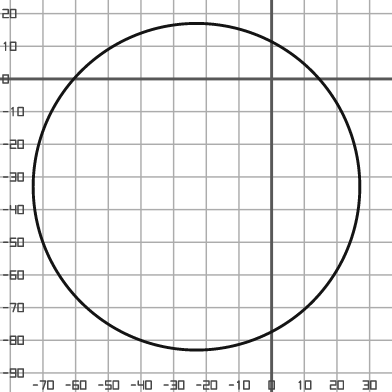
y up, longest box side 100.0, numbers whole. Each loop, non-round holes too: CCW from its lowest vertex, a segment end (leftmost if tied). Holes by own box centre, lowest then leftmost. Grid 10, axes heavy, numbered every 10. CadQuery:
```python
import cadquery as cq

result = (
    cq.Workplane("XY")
    .moveTo(-23.0, -33.0)
    .circle(50.0)
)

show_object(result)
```